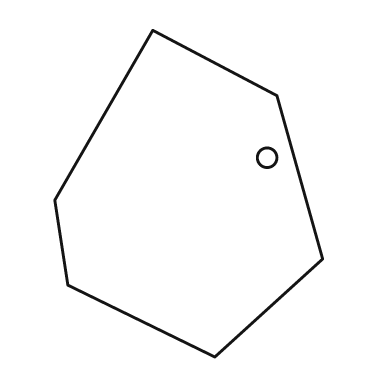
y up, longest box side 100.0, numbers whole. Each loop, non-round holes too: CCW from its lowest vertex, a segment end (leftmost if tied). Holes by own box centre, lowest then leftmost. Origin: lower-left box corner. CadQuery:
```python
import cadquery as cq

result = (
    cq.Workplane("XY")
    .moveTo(49.0, 0.0)
    .lineTo(82.0, 30.0)
    .lineTo(68.0, 80.0)
    .lineTo(30.0, 100.0)
    .lineTo(0.0, 48.0)
    .lineTo(4.0, 22.0)
    .close()
    .moveTo(65.0, 61.0)
    .circle(3.0)
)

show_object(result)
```